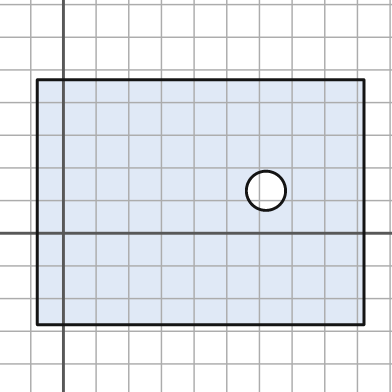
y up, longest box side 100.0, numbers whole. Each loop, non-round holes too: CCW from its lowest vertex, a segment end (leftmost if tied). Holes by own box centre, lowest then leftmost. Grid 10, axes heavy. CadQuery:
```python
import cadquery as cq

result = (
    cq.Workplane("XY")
    .moveTo(-8.0, -28.0)
    .lineTo(92.0, -28.0)
    .lineTo(92.0, 47.0)
    .lineTo(-8.0, 47.0)
    .close()
    .moveTo(62.0, 13.0)
    .circle(6.0)
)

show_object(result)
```